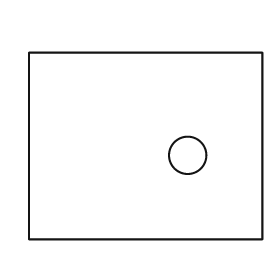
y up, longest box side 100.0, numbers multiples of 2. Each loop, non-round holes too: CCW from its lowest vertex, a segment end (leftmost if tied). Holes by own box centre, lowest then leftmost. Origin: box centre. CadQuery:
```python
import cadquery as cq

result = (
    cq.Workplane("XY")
    .moveTo(-50.0, -40.0)
    .lineTo(50.0, -40.0)
    .lineTo(50.0, 40.0)
    .lineTo(-50.0, 40.0)
    .close()
    .moveTo(18.0, -4.0)
    .circle(8.0)
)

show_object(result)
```